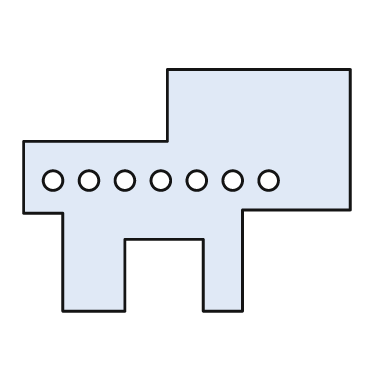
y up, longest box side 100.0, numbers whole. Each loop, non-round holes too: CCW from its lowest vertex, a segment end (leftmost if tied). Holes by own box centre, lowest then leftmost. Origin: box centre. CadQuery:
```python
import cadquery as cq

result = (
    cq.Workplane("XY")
    .moveTo(-38.0, -37.0)
    .lineTo(-19.0, -37.0)
    .lineTo(-19.0, -15.0)
    .lineTo(5.0, -15.0)
    .lineTo(5.0, -37.0)
    .lineTo(17.0, -37.0)
    .lineTo(17.0, -6.0)
    .lineTo(50.0, -6.0)
    .lineTo(50.0, 37.0)
    .lineTo(-6.0, 37.0)
    .lineTo(-6.0, 15.0)
    .lineTo(-50.0, 15.0)
    .lineTo(-50.0, -7.0)
    .lineTo(-38.0, -7.0)
    .close()
    .moveTo(-41.0, 3.0)
    .circle(3.0)
    .moveTo(-30.0, 3.0)
    .circle(3.0)
    .moveTo(-19.0, 3.0)
    .circle(3.0)
    .moveTo(-8.0, 3.0)
    .circle(3.0)
    .moveTo(3.0, 3.0)
    .circle(3.0)
    .moveTo(14.0, 3.0)
    .circle(3.0)
    .moveTo(25.0, 3.0)
    .circle(3.0)
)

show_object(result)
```